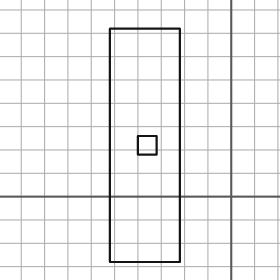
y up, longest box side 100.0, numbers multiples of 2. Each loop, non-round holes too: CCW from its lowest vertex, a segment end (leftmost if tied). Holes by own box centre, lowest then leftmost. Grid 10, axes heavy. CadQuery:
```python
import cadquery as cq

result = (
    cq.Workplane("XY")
    .moveTo(-52.0, -28.0)
    .lineTo(-22.0, -28.0)
    .lineTo(-22.0, 72.0)
    .lineTo(-52.0, 72.0)
    .close()
    .moveTo(-40.0, 18.0)
    .lineTo(-32.0, 18.0)
    .lineTo(-32.0, 26.0)
    .lineTo(-40.0, 26.0)
    .close()
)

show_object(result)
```